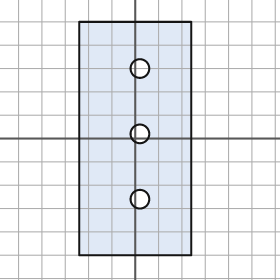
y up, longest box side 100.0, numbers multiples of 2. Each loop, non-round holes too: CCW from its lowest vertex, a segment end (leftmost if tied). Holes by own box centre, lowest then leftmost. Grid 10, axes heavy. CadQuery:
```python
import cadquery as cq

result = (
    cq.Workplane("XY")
    .moveTo(-24.0, -50.0)
    .lineTo(24.0, -50.0)
    .lineTo(24.0, 50.0)
    .lineTo(-24.0, 50.0)
    .close()
    .moveTo(2.0, -26.0)
    .circle(4.0)
    .moveTo(2.0, 2.0)
    .circle(4.0)
    .moveTo(2.0, 30.0)
    .circle(4.0)
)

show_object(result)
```